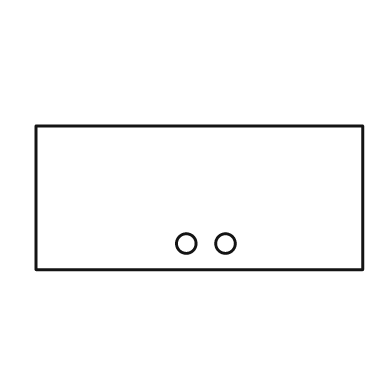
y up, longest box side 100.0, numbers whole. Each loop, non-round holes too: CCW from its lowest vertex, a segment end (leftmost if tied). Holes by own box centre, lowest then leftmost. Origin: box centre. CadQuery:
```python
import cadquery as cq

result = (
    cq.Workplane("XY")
    .moveTo(-50.0, -22.0)
    .lineTo(50.0, -22.0)
    .lineTo(50.0, 22.0)
    .lineTo(-50.0, 22.0)
    .close()
    .moveTo(-4.0, -14.0)
    .circle(3.0)
    .moveTo(8.0, -14.0)
    .circle(3.0)
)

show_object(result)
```